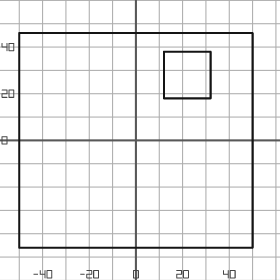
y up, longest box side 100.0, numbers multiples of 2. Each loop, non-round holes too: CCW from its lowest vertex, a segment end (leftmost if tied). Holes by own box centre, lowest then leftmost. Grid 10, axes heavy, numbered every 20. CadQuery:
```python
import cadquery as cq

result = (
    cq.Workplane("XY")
    .moveTo(-50.0, -46.0)
    .lineTo(50.0, -46.0)
    .lineTo(50.0, 46.0)
    .lineTo(-50.0, 46.0)
    .close()
    .moveTo(12.0, 18.0)
    .lineTo(32.0, 18.0)
    .lineTo(32.0, 38.0)
    .lineTo(12.0, 38.0)
    .close()
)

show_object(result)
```